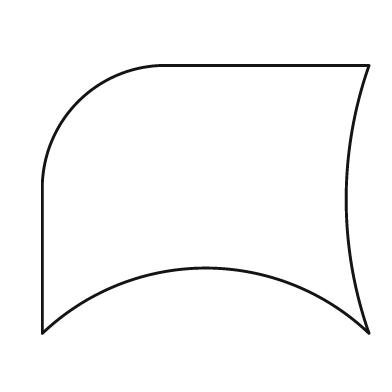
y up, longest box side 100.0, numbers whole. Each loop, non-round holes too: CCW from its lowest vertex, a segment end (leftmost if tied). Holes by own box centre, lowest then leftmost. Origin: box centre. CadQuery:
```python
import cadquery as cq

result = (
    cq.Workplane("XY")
    .moveTo(-50.0, -41.0)
    .threePointArc((0.0, -21.0), (50.0, -41.0))
    .threePointArc((43.0, 0.0), (50.0, 41.0))
    .lineTo(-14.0, 41.0)
    .threePointArc((-39.0, 30.0), (-50.0, 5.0))
    .close()
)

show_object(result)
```